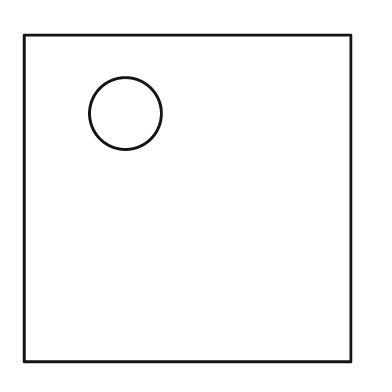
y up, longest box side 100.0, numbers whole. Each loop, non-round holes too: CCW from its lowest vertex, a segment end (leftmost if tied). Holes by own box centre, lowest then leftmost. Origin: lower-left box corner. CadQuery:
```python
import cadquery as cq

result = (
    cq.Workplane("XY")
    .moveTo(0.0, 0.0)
    .lineTo(100.0, 0.0)
    .lineTo(100.0, 100.0)
    .lineTo(0.0, 100.0)
    .close()
    .moveTo(31.0, 76.0)
    .circle(11.0)
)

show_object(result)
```